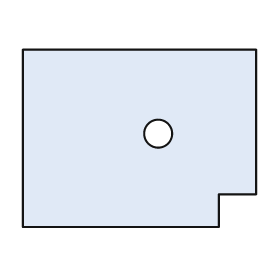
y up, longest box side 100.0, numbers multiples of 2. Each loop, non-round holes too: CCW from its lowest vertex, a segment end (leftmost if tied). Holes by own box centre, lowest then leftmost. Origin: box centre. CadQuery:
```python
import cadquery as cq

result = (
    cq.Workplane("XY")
    .moveTo(-50.0, -38.0)
    .lineTo(34.0, -38.0)
    .lineTo(34.0, -24.0)
    .lineTo(50.0, -24.0)
    .lineTo(50.0, 38.0)
    .lineTo(-50.0, 38.0)
    .close()
    .moveTo(8.0, 2.0)
    .circle(6.0)
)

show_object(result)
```